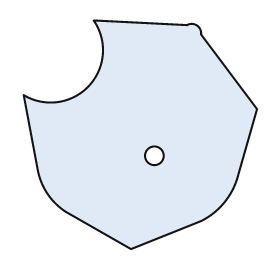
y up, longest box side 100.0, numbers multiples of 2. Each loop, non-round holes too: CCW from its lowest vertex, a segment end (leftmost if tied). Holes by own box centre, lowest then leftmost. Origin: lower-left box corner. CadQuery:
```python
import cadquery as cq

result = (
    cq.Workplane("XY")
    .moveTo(46.0, 0.0)
    .lineTo(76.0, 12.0)
    .threePointArc((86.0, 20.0), (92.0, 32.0))
    .lineTo(100.0, 60.0)
    .lineTo(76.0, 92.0)
    .threePointArc((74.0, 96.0), (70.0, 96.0))
    .lineTo(30.0, 98.0)
    .threePointArc((28.0, 70.0), (0.0, 66.0))
    .lineTo(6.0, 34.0)
    .threePointArc((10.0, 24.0), (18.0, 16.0))
    .close()
    .moveTo(56.0, 40.0)
    .circle(4.0)
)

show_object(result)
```